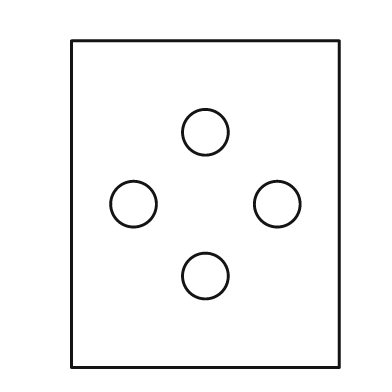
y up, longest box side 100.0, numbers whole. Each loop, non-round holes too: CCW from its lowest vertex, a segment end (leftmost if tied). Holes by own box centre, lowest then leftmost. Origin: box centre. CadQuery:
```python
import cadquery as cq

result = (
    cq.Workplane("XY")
    .moveTo(-41.0, -50.0)
    .lineTo(41.0, -50.0)
    .lineTo(41.0, 50.0)
    .lineTo(-41.0, 50.0)
    .close()
    .moveTo(0.0, -22.0)
    .circle(7.0)
    .moveTo(-22.0, 0.0)
    .circle(7.0)
    .moveTo(22.0, 0.0)
    .circle(7.0)
    .moveTo(0.0, 22.0)
    .circle(7.0)
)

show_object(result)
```